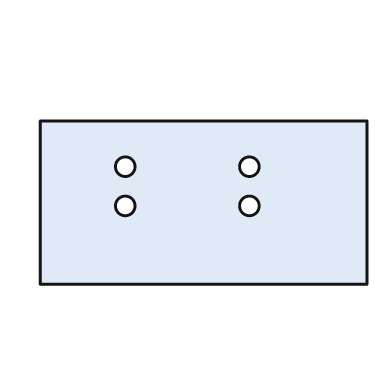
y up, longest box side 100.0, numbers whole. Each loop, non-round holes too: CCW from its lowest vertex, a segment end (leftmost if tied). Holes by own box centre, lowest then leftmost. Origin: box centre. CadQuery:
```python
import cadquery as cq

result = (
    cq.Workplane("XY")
    .moveTo(-50.0, -25.0)
    .lineTo(50.0, -25.0)
    .lineTo(50.0, 25.0)
    .lineTo(-50.0, 25.0)
    .close()
    .moveTo(-24.0, -1.0)
    .circle(3.0)
    .moveTo(14.0, -1.0)
    .circle(3.0)
    .moveTo(-24.0, 11.0)
    .circle(3.0)
    .moveTo(14.0, 11.0)
    .circle(3.0)
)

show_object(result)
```